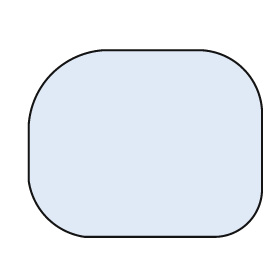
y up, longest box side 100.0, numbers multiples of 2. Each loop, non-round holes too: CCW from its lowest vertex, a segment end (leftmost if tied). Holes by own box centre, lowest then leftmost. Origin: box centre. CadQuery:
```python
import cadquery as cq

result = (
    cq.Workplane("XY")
    .moveTo(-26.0, -40.0)
    .lineTo(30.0, -40.0)
    .threePointArc((44.0, -34.0), (50.0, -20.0))
    .lineTo(50.0, 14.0)
    .threePointArc((42.0, 32.0), (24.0, 40.0))
    .lineTo(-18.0, 40.0)
    .threePointArc((-40.0, 30.0), (-50.0, 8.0))
    .lineTo(-50.0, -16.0)
    .threePointArc((-42.0, -32.0), (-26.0, -40.0))
    .close()
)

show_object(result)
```